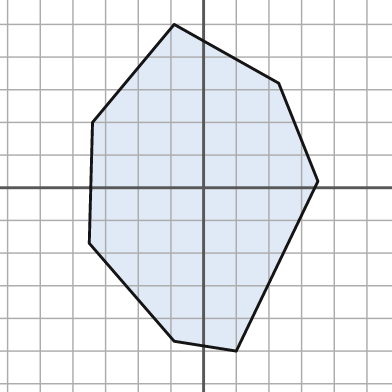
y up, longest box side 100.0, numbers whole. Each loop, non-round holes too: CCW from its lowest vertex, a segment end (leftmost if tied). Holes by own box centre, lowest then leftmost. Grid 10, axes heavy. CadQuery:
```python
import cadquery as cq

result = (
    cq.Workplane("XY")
    .moveTo(10.0, -50.0)
    .lineTo(35.0, 2.0)
    .lineTo(23.0, 32.0)
    .lineTo(-9.0, 50.0)
    .lineTo(-34.0, 20.0)
    .lineTo(-35.0, -17.0)
    .lineTo(-9.0, -47.0)
    .close()
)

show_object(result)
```